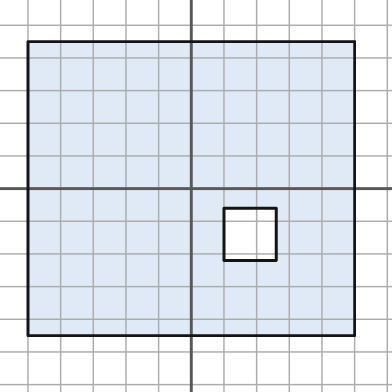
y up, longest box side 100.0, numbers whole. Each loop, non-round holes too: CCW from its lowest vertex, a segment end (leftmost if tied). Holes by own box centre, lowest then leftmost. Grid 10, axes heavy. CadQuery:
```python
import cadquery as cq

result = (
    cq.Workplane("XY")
    .moveTo(-50.0, -45.0)
    .lineTo(50.0, -45.0)
    .lineTo(50.0, 45.0)
    .lineTo(-50.0, 45.0)
    .close()
    .moveTo(10.0, -22.0)
    .lineTo(26.0, -22.0)
    .lineTo(26.0, -6.0)
    .lineTo(10.0, -6.0)
    .close()
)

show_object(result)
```